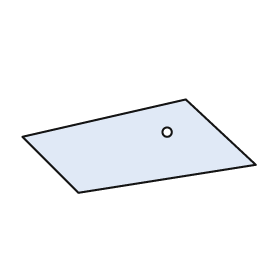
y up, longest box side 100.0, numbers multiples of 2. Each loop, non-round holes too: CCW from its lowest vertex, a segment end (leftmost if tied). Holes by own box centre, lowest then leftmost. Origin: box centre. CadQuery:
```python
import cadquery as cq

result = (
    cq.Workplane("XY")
    .moveTo(-26.0, -20.0)
    .lineTo(50.0, -8.0)
    .lineTo(20.0, 20.0)
    .lineTo(-50.0, 4.0)
    .close()
    .moveTo(12.0, 6.0)
    .circle(2.0)
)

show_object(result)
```